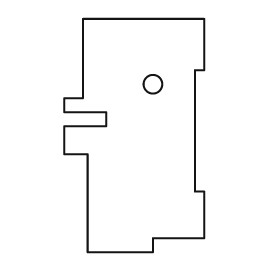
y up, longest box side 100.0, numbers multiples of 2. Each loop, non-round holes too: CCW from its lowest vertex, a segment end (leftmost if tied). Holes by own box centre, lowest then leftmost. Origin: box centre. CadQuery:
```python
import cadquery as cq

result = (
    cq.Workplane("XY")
    .moveTo(-20.0, -50.0)
    .lineTo(8.0, -50.0)
    .lineTo(8.0, -44.0)
    .lineTo(30.0, -44.0)
    .lineTo(30.0, -24.0)
    .lineTo(26.0, -24.0)
    .lineTo(26.0, 28.0)
    .lineTo(30.0, 28.0)
    .lineTo(30.0, 50.0)
    .lineTo(-22.0, 50.0)
    .lineTo(-22.0, 16.0)
    .lineTo(-30.0, 16.0)
    .lineTo(-30.0, 10.0)
    .lineTo(-12.0, 10.0)
    .lineTo(-12.0, 4.0)
    .lineTo(-30.0, 4.0)
    .lineTo(-30.0, -8.0)
    .lineTo(-20.0, -8.0)
    .close()
    .moveTo(8.0, 22.0)
    .circle(4.0)
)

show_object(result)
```